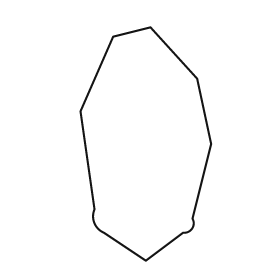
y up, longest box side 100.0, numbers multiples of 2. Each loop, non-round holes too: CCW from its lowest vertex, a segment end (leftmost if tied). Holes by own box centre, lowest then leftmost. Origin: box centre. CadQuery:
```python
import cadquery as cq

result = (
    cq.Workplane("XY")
    .moveTo(0.0, -50.0)
    .lineTo(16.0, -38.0)
    .threePointArc((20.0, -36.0), (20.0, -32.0))
    .lineTo(28.0, 0.0)
    .lineTo(22.0, 28.0)
    .lineTo(2.0, 50.0)
    .lineTo(-14.0, 46.0)
    .lineTo(-28.0, 14.0)
    .lineTo(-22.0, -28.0)
    .threePointArc((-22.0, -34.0), (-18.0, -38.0))
    .close()
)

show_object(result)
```